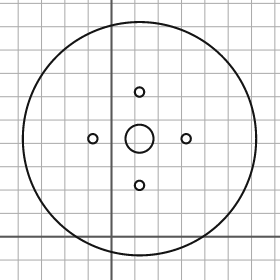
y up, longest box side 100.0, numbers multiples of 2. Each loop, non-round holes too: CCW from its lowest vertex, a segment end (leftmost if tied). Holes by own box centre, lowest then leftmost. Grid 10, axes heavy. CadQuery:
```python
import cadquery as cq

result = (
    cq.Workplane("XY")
    .moveTo(12.0, 42.0)
    .circle(50.0)
    .moveTo(12.0, 22.0)
    .circle(2.0)
    .moveTo(-8.0, 42.0)
    .circle(2.0)
    .moveTo(12.0, 42.0)
    .circle(6.0)
    .moveTo(32.0, 42.0)
    .circle(2.0)
    .moveTo(12.0, 62.0)
    .circle(2.0)
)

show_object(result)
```